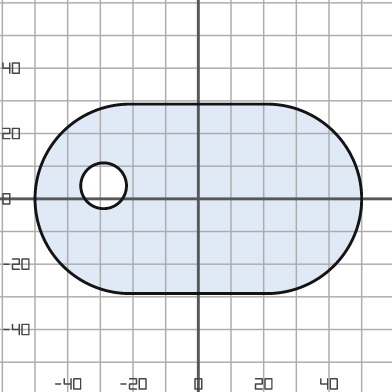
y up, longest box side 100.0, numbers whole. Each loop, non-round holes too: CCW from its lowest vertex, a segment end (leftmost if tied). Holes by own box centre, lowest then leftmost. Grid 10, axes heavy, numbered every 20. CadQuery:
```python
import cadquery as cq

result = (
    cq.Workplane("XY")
    .moveTo(-21.0, -29.0)
    .lineTo(21.0, -29.0)
    .threePointArc((50.0, 0.0), (21.0, 29.0))
    .lineTo(-21.0, 29.0)
    .threePointArc((-50.0, 0.0), (-21.0, -29.0))
    .close()
    .moveTo(-29.0, 4.0)
    .circle(7.0)
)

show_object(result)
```